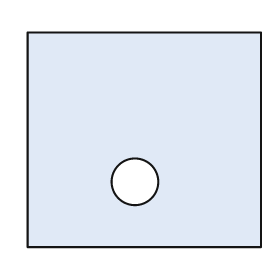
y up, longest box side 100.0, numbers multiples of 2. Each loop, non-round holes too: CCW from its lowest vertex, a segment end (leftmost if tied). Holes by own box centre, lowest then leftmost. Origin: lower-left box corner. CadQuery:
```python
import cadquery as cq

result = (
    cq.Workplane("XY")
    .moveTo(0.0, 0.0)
    .lineTo(100.0, 0.0)
    .lineTo(100.0, 92.0)
    .lineTo(0.0, 92.0)
    .close()
    .moveTo(46.0, 28.0)
    .circle(10.0)
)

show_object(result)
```